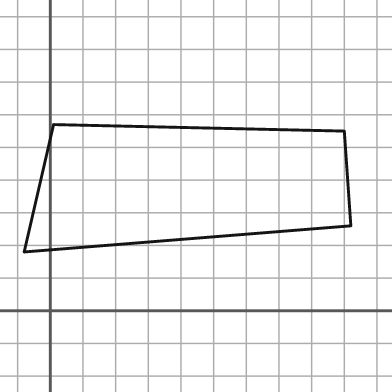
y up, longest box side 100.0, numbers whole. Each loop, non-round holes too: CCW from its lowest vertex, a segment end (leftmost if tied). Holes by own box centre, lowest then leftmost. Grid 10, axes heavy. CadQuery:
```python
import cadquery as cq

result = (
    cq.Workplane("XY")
    .moveTo(-8.0, 18.0)
    .lineTo(92.0, 26.0)
    .lineTo(90.0, 55.0)
    .lineTo(1.0, 57.0)
    .close()
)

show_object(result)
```